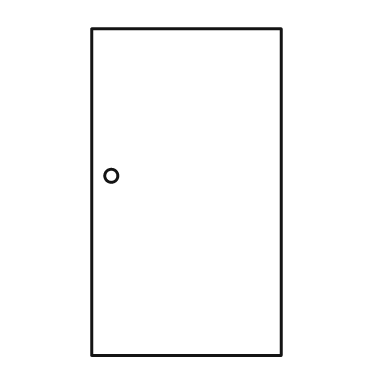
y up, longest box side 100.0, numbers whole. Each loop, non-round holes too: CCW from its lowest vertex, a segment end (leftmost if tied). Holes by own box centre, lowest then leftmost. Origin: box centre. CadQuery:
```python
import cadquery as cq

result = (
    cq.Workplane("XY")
    .moveTo(-29.0, -50.0)
    .lineTo(29.0, -50.0)
    .lineTo(29.0, 50.0)
    .lineTo(-29.0, 50.0)
    .close()
    .moveTo(-23.0, 5.0)
    .circle(2.0)
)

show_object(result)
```